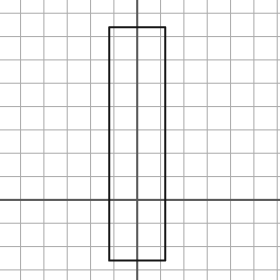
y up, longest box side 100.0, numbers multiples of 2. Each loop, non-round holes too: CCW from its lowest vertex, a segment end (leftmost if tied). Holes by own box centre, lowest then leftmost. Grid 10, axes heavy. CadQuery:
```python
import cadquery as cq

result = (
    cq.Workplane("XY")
    .moveTo(-12.0, -26.0)
    .lineTo(12.0, -26.0)
    .lineTo(12.0, 74.0)
    .lineTo(-12.0, 74.0)
    .close()
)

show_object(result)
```